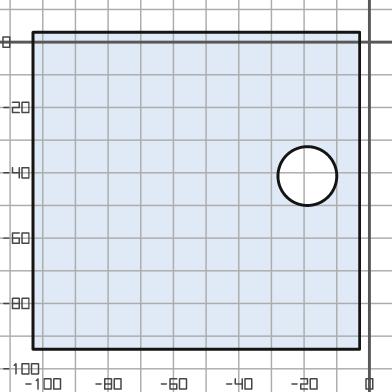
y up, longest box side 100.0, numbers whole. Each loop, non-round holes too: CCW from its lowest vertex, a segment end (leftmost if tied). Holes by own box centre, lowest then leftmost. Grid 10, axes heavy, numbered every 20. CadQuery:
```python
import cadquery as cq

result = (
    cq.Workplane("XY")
    .moveTo(-103.0, -94.0)
    .lineTo(-3.0, -94.0)
    .lineTo(-3.0, 3.0)
    .lineTo(-103.0, 3.0)
    .close()
    .moveTo(-19.0, -41.0)
    .circle(9.0)
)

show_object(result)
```